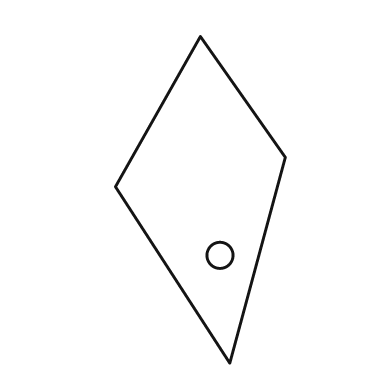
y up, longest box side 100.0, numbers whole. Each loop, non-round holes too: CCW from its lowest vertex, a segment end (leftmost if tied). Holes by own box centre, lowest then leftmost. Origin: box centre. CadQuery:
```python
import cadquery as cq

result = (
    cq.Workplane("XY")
    .moveTo(9.0, -50.0)
    .lineTo(26.0, 13.0)
    .lineTo(0.0, 50.0)
    .lineTo(-26.0, 4.0)
    .close()
    .moveTo(6.0, -17.0)
    .circle(4.0)
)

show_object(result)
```